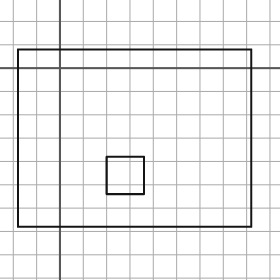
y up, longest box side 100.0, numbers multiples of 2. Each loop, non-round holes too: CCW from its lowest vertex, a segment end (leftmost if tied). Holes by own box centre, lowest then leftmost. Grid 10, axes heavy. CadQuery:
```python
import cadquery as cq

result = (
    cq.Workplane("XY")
    .moveTo(-18.0, -68.0)
    .lineTo(82.0, -68.0)
    .lineTo(82.0, 8.0)
    .lineTo(-18.0, 8.0)
    .close()
    .moveTo(20.0, -54.0)
    .lineTo(36.0, -54.0)
    .lineTo(36.0, -38.0)
    .lineTo(20.0, -38.0)
    .close()
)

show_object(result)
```